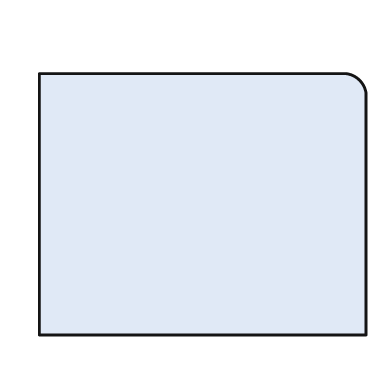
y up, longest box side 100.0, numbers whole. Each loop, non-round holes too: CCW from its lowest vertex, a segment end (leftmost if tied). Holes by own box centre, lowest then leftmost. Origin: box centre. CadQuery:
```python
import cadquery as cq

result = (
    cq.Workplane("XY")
    .moveTo(-50.0, -40.0)
    .lineTo(50.0, -40.0)
    .lineTo(50.0, 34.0)
    .threePointArc((48.0, 38.0), (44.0, 40.0))
    .lineTo(-50.0, 40.0)
    .close()
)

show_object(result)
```